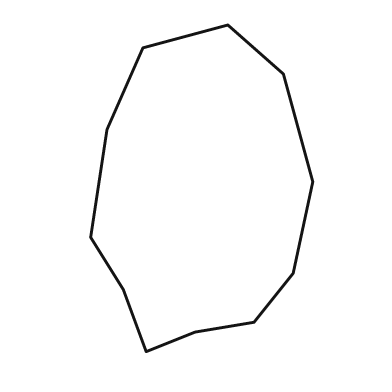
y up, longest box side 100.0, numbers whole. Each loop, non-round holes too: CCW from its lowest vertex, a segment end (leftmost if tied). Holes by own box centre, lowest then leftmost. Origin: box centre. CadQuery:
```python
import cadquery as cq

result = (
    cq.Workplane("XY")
    .moveTo(-17.0, -50.0)
    .lineTo(-2.0, -44.0)
    .lineTo(16.0, -41.0)
    .lineTo(28.0, -26.0)
    .lineTo(34.0, 2.0)
    .lineTo(25.0, 35.0)
    .lineTo(8.0, 50.0)
    .lineTo(-18.0, 43.0)
    .lineTo(-29.0, 18.0)
    .lineTo(-34.0, -15.0)
    .lineTo(-24.0, -31.0)
    .close()
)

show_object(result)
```